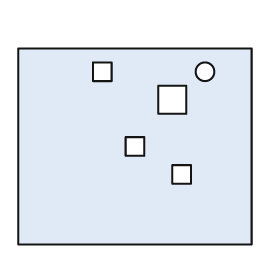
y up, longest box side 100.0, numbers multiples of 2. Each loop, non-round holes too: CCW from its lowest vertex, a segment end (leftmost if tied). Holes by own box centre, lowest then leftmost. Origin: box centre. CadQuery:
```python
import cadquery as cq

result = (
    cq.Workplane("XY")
    .moveTo(-50.0, -42.0)
    .lineTo(50.0, -42.0)
    .lineTo(50.0, 42.0)
    .lineTo(-50.0, 42.0)
    .close()
    .moveTo(16.0, -16.0)
    .lineTo(24.0, -16.0)
    .lineTo(24.0, -8.0)
    .lineTo(16.0, -8.0)
    .close()
    .moveTo(-4.0, -4.0)
    .lineTo(4.0, -4.0)
    .lineTo(4.0, 4.0)
    .lineTo(-4.0, 4.0)
    .close()
    .moveTo(10.0, 14.0)
    .lineTo(22.0, 14.0)
    .lineTo(22.0, 26.0)
    .lineTo(10.0, 26.0)
    .close()
    .moveTo(-18.0, 28.0)
    .lineTo(-10.0, 28.0)
    .lineTo(-10.0, 36.0)
    .lineTo(-18.0, 36.0)
    .close()
    .moveTo(30.0, 32.0)
    .circle(4.0)
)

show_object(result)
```